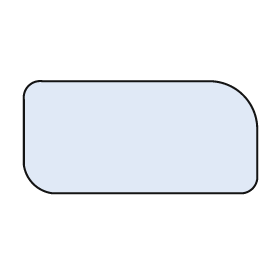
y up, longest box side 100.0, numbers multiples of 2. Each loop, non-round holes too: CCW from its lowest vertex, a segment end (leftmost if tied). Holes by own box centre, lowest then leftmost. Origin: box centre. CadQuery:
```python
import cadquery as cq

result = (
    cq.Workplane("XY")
    .moveTo(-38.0, -24.0)
    .lineTo(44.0, -24.0)
    .threePointArc((48.0, -22.0), (50.0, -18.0))
    .lineTo(50.0, 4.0)
    .threePointArc((44.0, 18.0), (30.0, 24.0))
    .lineTo(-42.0, 24.0)
    .threePointArc((-48.0, 22.0), (-50.0, 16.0))
    .lineTo(-50.0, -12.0)
    .threePointArc((-46.0, -20.0), (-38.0, -24.0))
    .close()
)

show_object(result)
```